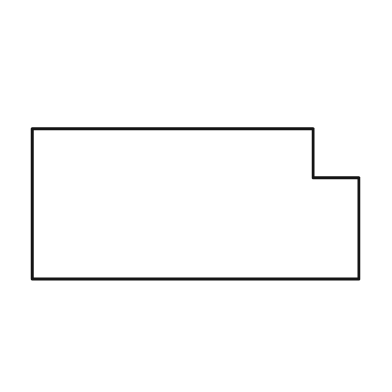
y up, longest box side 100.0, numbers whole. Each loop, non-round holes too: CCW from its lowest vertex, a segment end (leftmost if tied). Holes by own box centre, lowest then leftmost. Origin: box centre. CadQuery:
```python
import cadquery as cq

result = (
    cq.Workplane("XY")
    .moveTo(-50.0, -23.0)
    .lineTo(50.0, -23.0)
    .lineTo(50.0, 8.0)
    .lineTo(36.0, 8.0)
    .lineTo(36.0, 23.0)
    .lineTo(-50.0, 23.0)
    .close()
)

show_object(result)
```